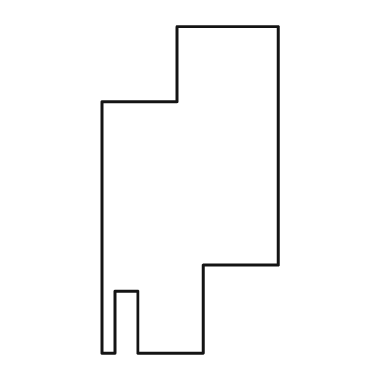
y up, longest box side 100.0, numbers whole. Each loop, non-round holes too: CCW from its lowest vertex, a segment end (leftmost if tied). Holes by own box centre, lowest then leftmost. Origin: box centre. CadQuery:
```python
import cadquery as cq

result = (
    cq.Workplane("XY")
    .moveTo(-27.0, -50.0)
    .lineTo(-23.0, -50.0)
    .lineTo(-23.0, -31.0)
    .lineTo(-16.0, -31.0)
    .lineTo(-16.0, -50.0)
    .lineTo(4.0, -50.0)
    .lineTo(4.0, -23.0)
    .lineTo(27.0, -23.0)
    .lineTo(27.0, 50.0)
    .lineTo(-4.0, 50.0)
    .lineTo(-4.0, 27.0)
    .lineTo(-27.0, 27.0)
    .close()
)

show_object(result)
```